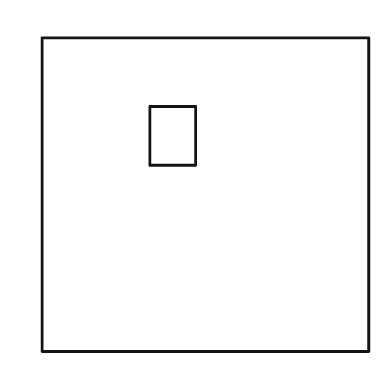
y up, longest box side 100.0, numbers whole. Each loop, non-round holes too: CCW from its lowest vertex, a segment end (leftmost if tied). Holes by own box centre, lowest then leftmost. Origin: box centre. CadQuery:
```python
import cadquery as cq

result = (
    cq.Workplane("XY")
    .moveTo(-50.0, -48.0)
    .lineTo(50.0, -48.0)
    .lineTo(50.0, 48.0)
    .lineTo(-50.0, 48.0)
    .close()
    .moveTo(-17.0, 9.0)
    .lineTo(-3.0, 9.0)
    .lineTo(-3.0, 27.0)
    .lineTo(-17.0, 27.0)
    .close()
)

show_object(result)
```